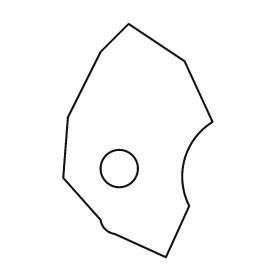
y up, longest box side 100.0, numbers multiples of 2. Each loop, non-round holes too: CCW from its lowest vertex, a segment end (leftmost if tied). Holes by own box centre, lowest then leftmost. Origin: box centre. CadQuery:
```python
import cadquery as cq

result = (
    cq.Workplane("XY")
    .moveTo(12.0, -50.0)
    .lineTo(22.0, -28.0)
    .threePointArc((20.0, -8.0), (32.0, 8.0))
    .lineTo(20.0, 34.0)
    .lineTo(-4.0, 50.0)
    .lineTo(-16.0, 38.0)
    .lineTo(-30.0, 10.0)
    .lineTo(-32.0, -16.0)
    .lineTo(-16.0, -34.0)
    .threePointArc((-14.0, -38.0), (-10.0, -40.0))
    .close()
    .moveTo(-8.0, -12.0)
    .circle(8.0)
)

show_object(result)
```